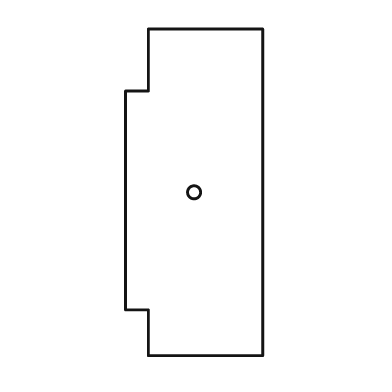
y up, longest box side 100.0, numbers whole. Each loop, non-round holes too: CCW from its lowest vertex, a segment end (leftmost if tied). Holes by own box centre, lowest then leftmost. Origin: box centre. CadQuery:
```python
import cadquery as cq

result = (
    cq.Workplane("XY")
    .moveTo(-14.0, -50.0)
    .lineTo(21.0, -50.0)
    .lineTo(21.0, 50.0)
    .lineTo(-14.0, 50.0)
    .lineTo(-14.0, 31.0)
    .lineTo(-21.0, 31.0)
    .lineTo(-21.0, -36.0)
    .lineTo(-14.0, -36.0)
    .close()
    .moveTo(0.0, 0.0)
    .circle(2.0)
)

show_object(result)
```